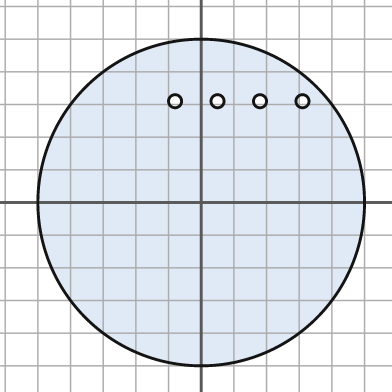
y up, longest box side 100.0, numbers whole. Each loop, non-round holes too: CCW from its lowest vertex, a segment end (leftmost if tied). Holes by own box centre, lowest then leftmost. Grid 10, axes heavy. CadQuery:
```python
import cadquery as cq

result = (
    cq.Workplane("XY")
    .moveTo(0.0, 0.0)
    .circle(50.0)
    .moveTo(-8.0, 31.0)
    .circle(2.0)
    .moveTo(5.0, 31.0)
    .circle(2.0)
    .moveTo(18.0, 31.0)
    .circle(2.0)
    .moveTo(31.0, 31.0)
    .circle(2.0)
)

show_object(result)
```